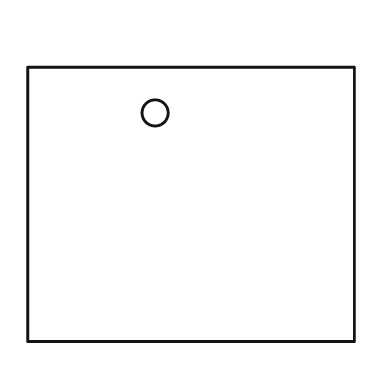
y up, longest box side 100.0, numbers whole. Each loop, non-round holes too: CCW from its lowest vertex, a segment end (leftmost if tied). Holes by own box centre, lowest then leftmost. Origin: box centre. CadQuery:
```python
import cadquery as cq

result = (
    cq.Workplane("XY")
    .moveTo(-50.0, -42.0)
    .lineTo(50.0, -42.0)
    .lineTo(50.0, 42.0)
    .lineTo(-50.0, 42.0)
    .close()
    .moveTo(-11.0, 28.0)
    .circle(4.0)
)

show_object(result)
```